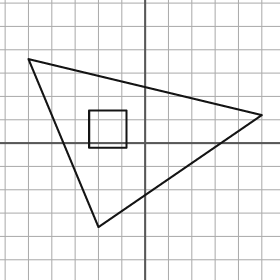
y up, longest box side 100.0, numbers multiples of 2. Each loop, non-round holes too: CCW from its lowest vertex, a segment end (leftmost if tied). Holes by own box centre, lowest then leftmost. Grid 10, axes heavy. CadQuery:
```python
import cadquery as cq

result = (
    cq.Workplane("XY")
    .moveTo(-20.0, -36.0)
    .lineTo(50.0, 12.0)
    .lineTo(-50.0, 36.0)
    .close()
    .moveTo(-24.0, -2.0)
    .lineTo(-8.0, -2.0)
    .lineTo(-8.0, 14.0)
    .lineTo(-24.0, 14.0)
    .close()
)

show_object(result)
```